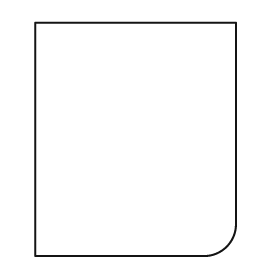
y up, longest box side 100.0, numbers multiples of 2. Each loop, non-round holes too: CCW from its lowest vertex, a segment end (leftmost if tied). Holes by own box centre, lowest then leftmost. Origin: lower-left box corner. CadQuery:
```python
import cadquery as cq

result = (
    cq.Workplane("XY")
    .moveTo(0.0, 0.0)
    .lineTo(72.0, 0.0)
    .threePointArc((82.0, 4.0), (86.0, 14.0))
    .lineTo(86.0, 100.0)
    .lineTo(0.0, 100.0)
    .close()
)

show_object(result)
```